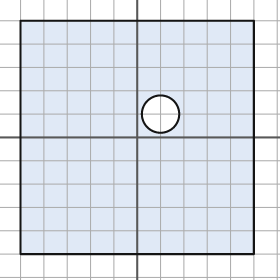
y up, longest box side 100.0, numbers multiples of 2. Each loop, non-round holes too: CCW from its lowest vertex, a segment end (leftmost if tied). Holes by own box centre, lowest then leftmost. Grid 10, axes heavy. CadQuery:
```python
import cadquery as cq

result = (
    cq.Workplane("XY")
    .moveTo(-50.0, -50.0)
    .lineTo(50.0, -50.0)
    .lineTo(50.0, 50.0)
    .lineTo(-50.0, 50.0)
    .close()
    .moveTo(10.0, 10.0)
    .circle(8.0)
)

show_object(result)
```